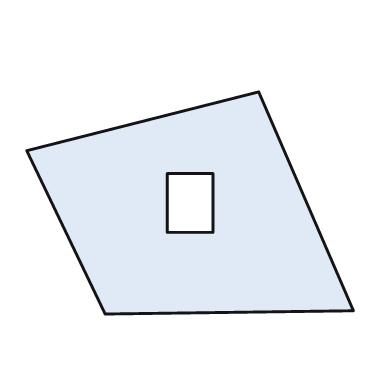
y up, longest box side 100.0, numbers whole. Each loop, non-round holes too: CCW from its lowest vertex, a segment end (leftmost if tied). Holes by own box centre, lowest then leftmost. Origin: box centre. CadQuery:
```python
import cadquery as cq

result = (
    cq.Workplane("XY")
    .moveTo(-26.0, -34.0)
    .lineTo(50.0, -33.0)
    .lineTo(21.0, 34.0)
    .lineTo(-50.0, 16.0)
    .close()
    .moveTo(-7.0, -9.0)
    .lineTo(7.0, -9.0)
    .lineTo(7.0, 9.0)
    .lineTo(-7.0, 9.0)
    .close()
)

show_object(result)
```